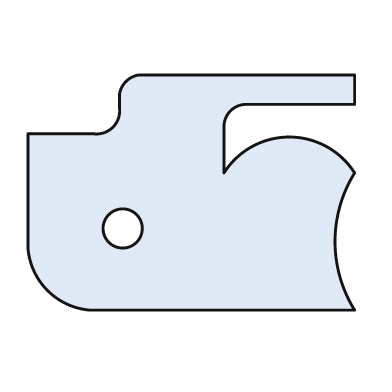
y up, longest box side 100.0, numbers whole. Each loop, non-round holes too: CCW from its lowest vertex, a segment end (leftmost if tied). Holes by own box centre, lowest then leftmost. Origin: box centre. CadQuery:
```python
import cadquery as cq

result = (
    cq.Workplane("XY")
    .moveTo(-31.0, -36.0)
    .lineTo(50.0, -36.0)
    .threePointArc((44.0, -15.0), (50.0, 6.0))
    .threePointArc((30.0, 17.0), (10.0, 6.0))
    .lineTo(10.0, 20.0)
    .threePointArc((12.0, 25.0), (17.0, 27.0))
    .lineTo(50.0, 27.0)
    .lineTo(50.0, 36.0)
    .lineTo(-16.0, 36.0)
    .threePointArc((-20.0, 34.0), (-22.0, 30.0))
    .lineTo(-22.0, 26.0)
    .threePointArc((-24.0, 20.0), (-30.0, 18.0))
    .lineTo(-50.0, 18.0)
    .lineTo(-50.0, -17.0)
    .threePointArc((-44.0, -30.0), (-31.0, -36.0))
    .close()
    .moveTo(-21.0, -11.0)
    .circle(6.0)
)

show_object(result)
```